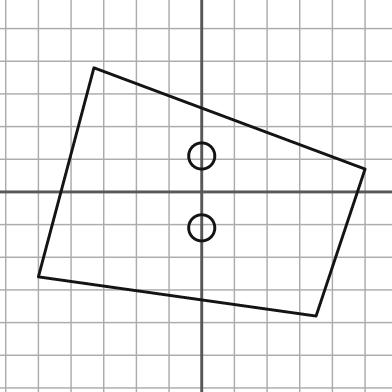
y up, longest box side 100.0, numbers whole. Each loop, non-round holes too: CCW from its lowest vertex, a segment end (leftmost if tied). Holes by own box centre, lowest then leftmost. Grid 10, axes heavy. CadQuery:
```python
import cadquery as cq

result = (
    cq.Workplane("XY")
    .moveTo(35.0, -38.0)
    .lineTo(50.0, 7.0)
    .lineTo(-33.0, 38.0)
    .lineTo(-50.0, -26.0)
    .close()
    .moveTo(0.0, -11.0)
    .circle(4.0)
    .moveTo(0.0, 11.0)
    .circle(4.0)
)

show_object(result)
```